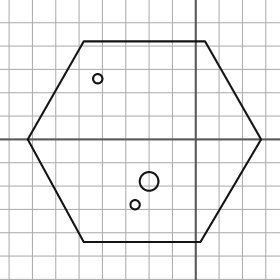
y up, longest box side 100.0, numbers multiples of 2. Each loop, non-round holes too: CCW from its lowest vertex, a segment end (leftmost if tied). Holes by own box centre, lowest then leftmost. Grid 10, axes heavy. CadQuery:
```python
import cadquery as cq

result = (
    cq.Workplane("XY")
    .moveTo(-48.0, -44.0)
    .lineTo(2.0, -44.0)
    .lineTo(28.0, 0.0)
    .lineTo(4.0, 42.0)
    .lineTo(-48.0, 42.0)
    .lineTo(-72.0, 0.0)
    .close()
    .moveTo(-26.0, -28.0)
    .circle(2.0)
    .moveTo(-20.0, -18.0)
    .circle(4.0)
    .moveTo(-42.0, 26.0)
    .circle(2.0)
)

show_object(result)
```